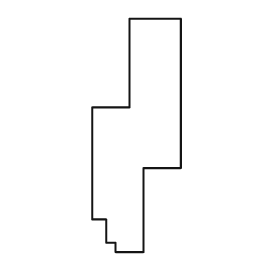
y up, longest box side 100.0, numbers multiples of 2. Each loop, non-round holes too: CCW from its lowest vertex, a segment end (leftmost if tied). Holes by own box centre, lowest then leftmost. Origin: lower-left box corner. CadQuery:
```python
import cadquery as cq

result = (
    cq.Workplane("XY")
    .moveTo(10.0, 0.0)
    .lineTo(22.0, 0.0)
    .lineTo(22.0, 36.0)
    .lineTo(38.0, 36.0)
    .lineTo(38.0, 100.0)
    .lineTo(16.0, 100.0)
    .lineTo(16.0, 62.0)
    .lineTo(0.0, 62.0)
    .lineTo(0.0, 14.0)
    .lineTo(6.0, 14.0)
    .lineTo(6.0, 4.0)
    .lineTo(10.0, 4.0)
    .close()
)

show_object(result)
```